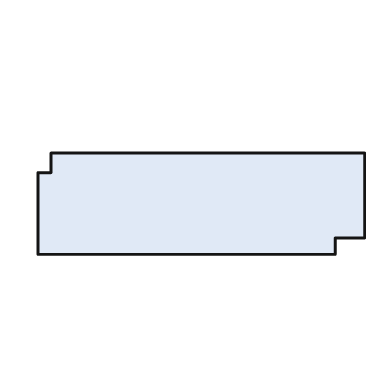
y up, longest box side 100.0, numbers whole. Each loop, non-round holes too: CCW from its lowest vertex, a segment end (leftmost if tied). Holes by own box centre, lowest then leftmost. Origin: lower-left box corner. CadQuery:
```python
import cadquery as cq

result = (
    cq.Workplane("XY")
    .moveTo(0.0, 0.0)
    .lineTo(91.0, 0.0)
    .lineTo(91.0, 5.0)
    .lineTo(100.0, 5.0)
    .lineTo(100.0, 31.0)
    .lineTo(4.0, 31.0)
    .lineTo(4.0, 25.0)
    .lineTo(0.0, 25.0)
    .close()
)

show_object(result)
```